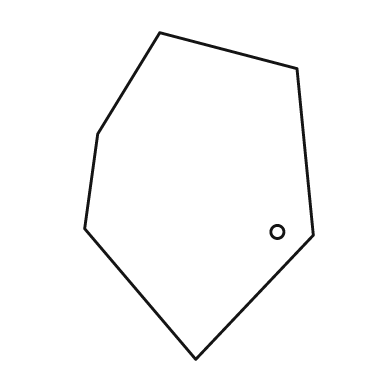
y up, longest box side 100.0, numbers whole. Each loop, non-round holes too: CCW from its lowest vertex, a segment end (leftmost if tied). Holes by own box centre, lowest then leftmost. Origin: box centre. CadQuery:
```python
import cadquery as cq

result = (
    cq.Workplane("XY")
    .moveTo(-1.0, -50.0)
    .lineTo(35.0, -12.0)
    .lineTo(30.0, 39.0)
    .lineTo(-12.0, 50.0)
    .lineTo(-31.0, 19.0)
    .lineTo(-35.0, -10.0)
    .close()
    .moveTo(24.0, -11.0)
    .circle(2.0)
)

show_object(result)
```